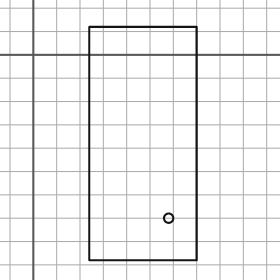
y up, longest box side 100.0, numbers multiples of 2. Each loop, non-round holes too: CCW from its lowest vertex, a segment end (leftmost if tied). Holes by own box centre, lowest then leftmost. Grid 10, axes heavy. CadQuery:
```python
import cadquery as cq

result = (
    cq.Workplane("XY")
    .moveTo(24.0, -88.0)
    .lineTo(70.0, -88.0)
    .lineTo(70.0, 12.0)
    .lineTo(24.0, 12.0)
    .close()
    .moveTo(58.0, -70.0)
    .circle(2.0)
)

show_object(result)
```